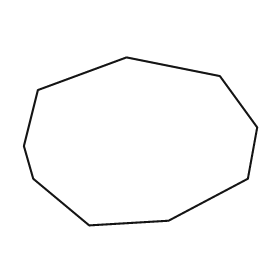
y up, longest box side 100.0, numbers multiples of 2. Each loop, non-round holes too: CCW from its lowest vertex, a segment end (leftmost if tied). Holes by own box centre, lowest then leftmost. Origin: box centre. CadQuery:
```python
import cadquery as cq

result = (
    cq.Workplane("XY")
    .moveTo(-22.0, -36.0)
    .lineTo(12.0, -34.0)
    .lineTo(46.0, -16.0)
    .lineTo(50.0, 6.0)
    .lineTo(34.0, 28.0)
    .lineTo(-6.0, 36.0)
    .lineTo(-44.0, 22.0)
    .lineTo(-50.0, -2.0)
    .lineTo(-46.0, -16.0)
    .close()
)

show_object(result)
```